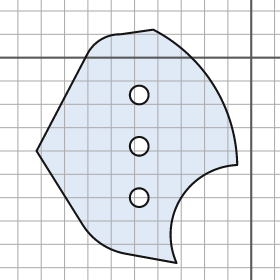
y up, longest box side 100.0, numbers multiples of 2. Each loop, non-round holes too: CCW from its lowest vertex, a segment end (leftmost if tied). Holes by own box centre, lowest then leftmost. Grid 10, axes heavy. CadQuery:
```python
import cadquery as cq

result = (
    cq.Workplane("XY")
    .moveTo(-32.0, -88.0)
    .threePointArc((-30.0, -60.0), (-6.0, -46.0))
    .threePointArc((-16.0, -12.0), (-42.0, 12.0))
    .lineTo(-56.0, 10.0)
    .threePointArc((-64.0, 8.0), (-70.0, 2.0))
    .lineTo(-92.0, -40.0)
    .lineTo(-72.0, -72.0)
    .threePointArc((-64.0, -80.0), (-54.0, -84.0))
    .close()
    .moveTo(-48.0, -60.0)
    .circle(4.0)
    .moveTo(-48.0, -38.0)
    .circle(4.0)
    .moveTo(-48.0, -16.0)
    .circle(4.0)
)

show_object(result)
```